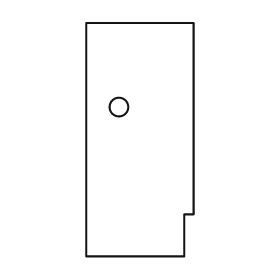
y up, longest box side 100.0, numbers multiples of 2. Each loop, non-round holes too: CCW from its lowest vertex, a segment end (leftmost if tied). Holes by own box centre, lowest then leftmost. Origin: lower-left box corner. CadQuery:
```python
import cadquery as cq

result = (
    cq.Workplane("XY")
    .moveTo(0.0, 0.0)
    .lineTo(42.0, 0.0)
    .lineTo(42.0, 18.0)
    .lineTo(46.0, 18.0)
    .lineTo(46.0, 100.0)
    .lineTo(0.0, 100.0)
    .close()
    .moveTo(14.0, 64.0)
    .circle(4.0)
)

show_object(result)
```